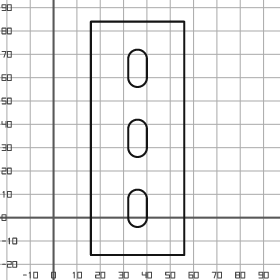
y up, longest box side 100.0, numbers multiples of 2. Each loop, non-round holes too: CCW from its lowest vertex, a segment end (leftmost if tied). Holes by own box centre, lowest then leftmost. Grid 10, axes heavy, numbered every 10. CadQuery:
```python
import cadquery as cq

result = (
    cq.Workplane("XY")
    .moveTo(16.0, -16.0)
    .lineTo(56.0, -16.0)
    .lineTo(56.0, 84.0)
    .lineTo(16.0, 84.0)
    .close()
    .moveTo(32.0, 0.0)
    .threePointArc((36.0, -4.0), (40.0, 0.0))
    .lineTo(40.0, 8.0)
    .threePointArc((36.0, 12.0), (32.0, 8.0))
    .close()
    .moveTo(32.0, 30.0)
    .threePointArc((36.0, 26.0), (40.0, 30.0))
    .lineTo(40.0, 38.0)
    .threePointArc((36.0, 42.0), (32.0, 38.0))
    .close()
    .moveTo(32.0, 60.0)
    .threePointArc((36.0, 56.0), (40.0, 60.0))
    .lineTo(40.0, 68.0)
    .threePointArc((36.0, 72.0), (32.0, 68.0))
    .close()
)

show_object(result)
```